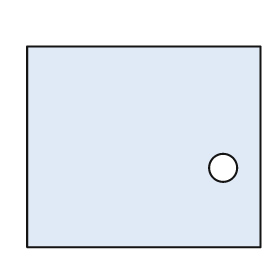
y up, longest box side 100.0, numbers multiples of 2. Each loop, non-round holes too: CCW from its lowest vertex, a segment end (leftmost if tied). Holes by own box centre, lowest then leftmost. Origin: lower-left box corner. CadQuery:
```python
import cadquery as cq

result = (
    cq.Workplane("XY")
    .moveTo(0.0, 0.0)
    .lineTo(100.0, 0.0)
    .lineTo(100.0, 86.0)
    .lineTo(0.0, 86.0)
    .close()
    .moveTo(84.0, 34.0)
    .circle(6.0)
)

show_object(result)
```